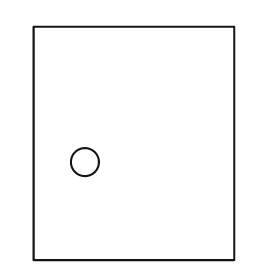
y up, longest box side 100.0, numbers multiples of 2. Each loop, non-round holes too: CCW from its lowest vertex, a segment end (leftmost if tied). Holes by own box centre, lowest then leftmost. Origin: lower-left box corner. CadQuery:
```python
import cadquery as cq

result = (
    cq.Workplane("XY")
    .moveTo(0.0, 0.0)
    .lineTo(86.0, 0.0)
    .lineTo(86.0, 100.0)
    .lineTo(0.0, 100.0)
    .close()
    .moveTo(22.0, 42.0)
    .circle(6.0)
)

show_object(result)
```